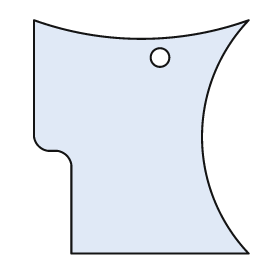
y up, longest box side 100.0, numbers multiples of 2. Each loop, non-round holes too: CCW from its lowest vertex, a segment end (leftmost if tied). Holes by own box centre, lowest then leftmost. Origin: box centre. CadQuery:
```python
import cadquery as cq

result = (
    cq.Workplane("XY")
    .moveTo(-30.0, -50.0)
    .lineTo(46.0, -50.0)
    .threePointArc((26.0, 0.0), (46.0, 50.0))
    .threePointArc((0.0, 42.0), (-46.0, 50.0))
    .lineTo(-46.0, 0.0)
    .threePointArc((-44.0, -4.0), (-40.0, -6.0))
    .lineTo(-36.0, -6.0)
    .threePointArc((-32.0, -8.0), (-30.0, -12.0))
    .close()
    .moveTo(8.0, 34.0)
    .circle(4.0)
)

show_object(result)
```